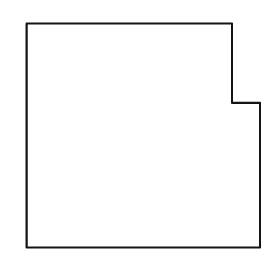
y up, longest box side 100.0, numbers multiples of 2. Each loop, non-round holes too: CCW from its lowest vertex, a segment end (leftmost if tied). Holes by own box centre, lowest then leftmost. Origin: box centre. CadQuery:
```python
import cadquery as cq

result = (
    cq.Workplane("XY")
    .moveTo(-50.0, -48.0)
    .lineTo(50.0, -48.0)
    .lineTo(50.0, 14.0)
    .lineTo(38.0, 14.0)
    .lineTo(38.0, 48.0)
    .lineTo(-50.0, 48.0)
    .close()
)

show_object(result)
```